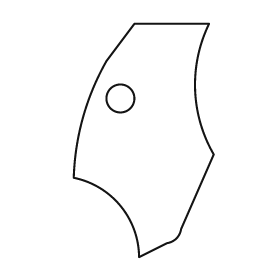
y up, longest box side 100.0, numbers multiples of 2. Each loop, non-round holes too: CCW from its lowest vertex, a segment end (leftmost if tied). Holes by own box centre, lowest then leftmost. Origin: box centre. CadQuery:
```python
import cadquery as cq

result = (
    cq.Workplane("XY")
    .moveTo(-2.0, -50.0)
    .lineTo(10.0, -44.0)
    .threePointArc((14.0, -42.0), (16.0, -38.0))
    .lineTo(30.0, -6.0)
    .threePointArc((22.0, 22.0), (28.0, 50.0))
    .lineTo(-4.0, 50.0)
    .lineTo(-16.0, 34.0)
    .threePointArc((-26.0, 10.0), (-30.0, -16.0))
    .threePointArc((-10.0, -28.0), (-2.0, -50.0))
    .close()
    .moveTo(-10.0, 18.0)
    .circle(6.0)
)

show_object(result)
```